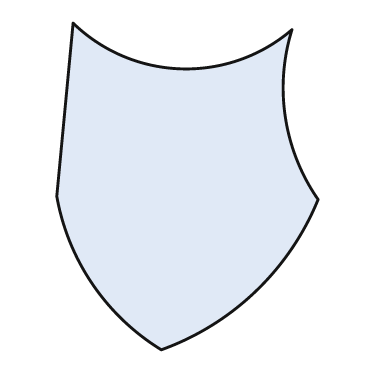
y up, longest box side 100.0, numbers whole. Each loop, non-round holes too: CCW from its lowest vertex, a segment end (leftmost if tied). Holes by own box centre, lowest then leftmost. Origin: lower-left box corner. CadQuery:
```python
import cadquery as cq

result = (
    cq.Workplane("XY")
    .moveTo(32.0, 0.0)
    .threePointArc((61.0, 18.0), (80.0, 46.0))
    .threePointArc((70.0, 71.0), (72.0, 98.0))
    .threePointArc((38.0, 86.0), (5.0, 100.0))
    .lineTo(0.0, 47.0)
    .threePointArc((11.0, 20.0), (32.0, 0.0))
    .close()
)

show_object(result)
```